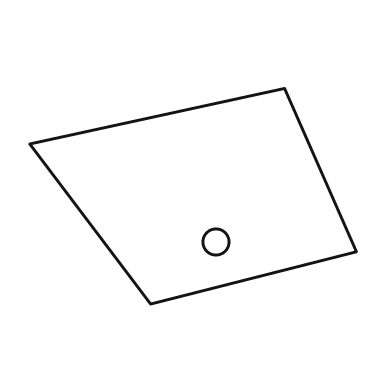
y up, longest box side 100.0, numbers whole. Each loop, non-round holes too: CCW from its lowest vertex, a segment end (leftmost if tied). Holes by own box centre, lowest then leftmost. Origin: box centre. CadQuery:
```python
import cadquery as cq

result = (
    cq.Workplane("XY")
    .moveTo(-13.0, -33.0)
    .lineTo(50.0, -17.0)
    .lineTo(28.0, 33.0)
    .lineTo(-50.0, 16.0)
    .close()
    .moveTo(7.0, -14.0)
    .circle(4.0)
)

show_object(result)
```